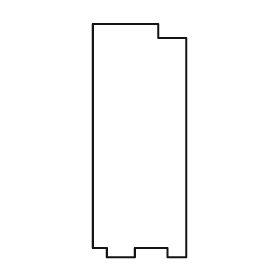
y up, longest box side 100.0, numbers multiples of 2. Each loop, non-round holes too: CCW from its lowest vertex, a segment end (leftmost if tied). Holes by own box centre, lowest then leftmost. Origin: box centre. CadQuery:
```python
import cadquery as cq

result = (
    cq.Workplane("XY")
    .moveTo(-14.0, -50.0)
    .lineTo(-2.0, -50.0)
    .lineTo(-2.0, -46.0)
    .lineTo(12.0, -46.0)
    .lineTo(12.0, -50.0)
    .lineTo(20.0, -50.0)
    .lineTo(20.0, 44.0)
    .lineTo(8.0, 44.0)
    .lineTo(8.0, 50.0)
    .lineTo(-20.0, 50.0)
    .lineTo(-20.0, -46.0)
    .lineTo(-14.0, -46.0)
    .close()
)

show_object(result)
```